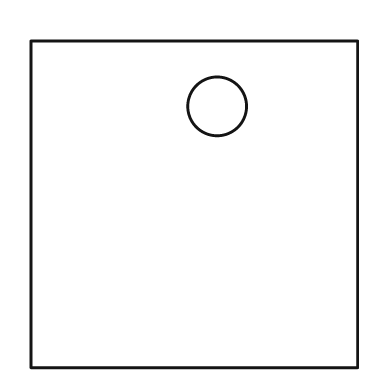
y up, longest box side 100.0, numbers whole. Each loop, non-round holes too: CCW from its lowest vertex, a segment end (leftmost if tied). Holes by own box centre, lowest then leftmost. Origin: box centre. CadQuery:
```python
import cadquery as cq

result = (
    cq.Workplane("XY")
    .moveTo(-50.0, -50.0)
    .lineTo(50.0, -50.0)
    .lineTo(50.0, 50.0)
    .lineTo(-50.0, 50.0)
    .close()
    .moveTo(7.0, 30.0)
    .circle(9.0)
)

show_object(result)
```